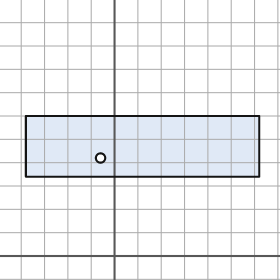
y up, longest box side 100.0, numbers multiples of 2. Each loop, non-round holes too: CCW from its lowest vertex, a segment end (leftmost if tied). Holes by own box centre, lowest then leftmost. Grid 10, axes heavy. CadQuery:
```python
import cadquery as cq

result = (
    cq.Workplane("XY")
    .moveTo(-38.0, 34.0)
    .lineTo(62.0, 34.0)
    .lineTo(62.0, 60.0)
    .lineTo(-38.0, 60.0)
    .close()
    .moveTo(-6.0, 42.0)
    .circle(2.0)
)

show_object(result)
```